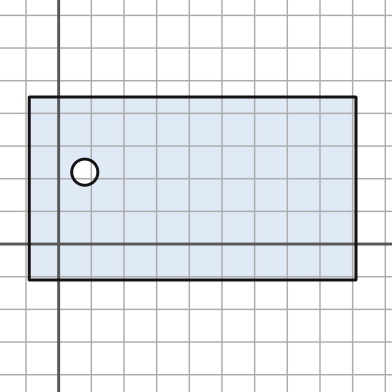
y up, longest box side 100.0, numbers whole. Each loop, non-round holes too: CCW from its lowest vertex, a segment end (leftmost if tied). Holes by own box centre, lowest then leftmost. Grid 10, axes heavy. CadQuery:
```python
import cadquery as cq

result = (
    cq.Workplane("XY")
    .moveTo(-9.0, -11.0)
    .lineTo(91.0, -11.0)
    .lineTo(91.0, 45.0)
    .lineTo(-9.0, 45.0)
    .close()
    .moveTo(8.0, 22.0)
    .circle(4.0)
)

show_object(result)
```